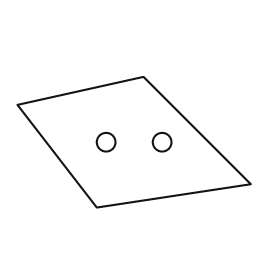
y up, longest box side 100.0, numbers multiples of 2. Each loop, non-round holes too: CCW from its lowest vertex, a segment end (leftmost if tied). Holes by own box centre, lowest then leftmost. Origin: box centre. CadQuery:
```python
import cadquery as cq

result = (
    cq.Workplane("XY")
    .moveTo(-16.0, -28.0)
    .lineTo(50.0, -18.0)
    .lineTo(4.0, 28.0)
    .lineTo(-50.0, 16.0)
    .close()
    .moveTo(-12.0, 0.0)
    .circle(4.0)
    .moveTo(12.0, 0.0)
    .circle(4.0)
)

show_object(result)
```